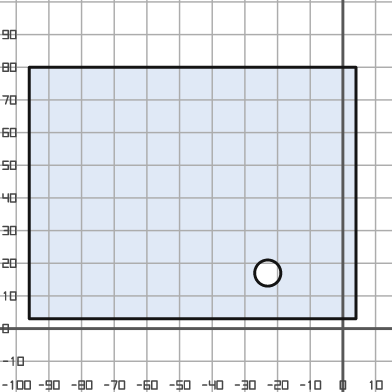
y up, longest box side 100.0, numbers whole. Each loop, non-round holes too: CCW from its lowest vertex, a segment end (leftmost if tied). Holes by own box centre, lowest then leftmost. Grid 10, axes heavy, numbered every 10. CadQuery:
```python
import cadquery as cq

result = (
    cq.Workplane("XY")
    .moveTo(-96.0, 3.0)
    .lineTo(4.0, 3.0)
    .lineTo(4.0, 80.0)
    .lineTo(-96.0, 80.0)
    .close()
    .moveTo(-23.0, 17.0)
    .circle(4.0)
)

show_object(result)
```